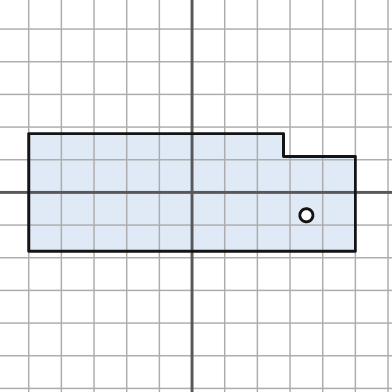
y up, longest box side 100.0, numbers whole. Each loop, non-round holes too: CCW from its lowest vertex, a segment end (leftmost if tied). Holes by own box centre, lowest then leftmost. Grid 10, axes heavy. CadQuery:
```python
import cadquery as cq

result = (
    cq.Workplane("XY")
    .moveTo(-50.0, -18.0)
    .lineTo(50.0, -18.0)
    .lineTo(50.0, 11.0)
    .lineTo(28.0, 11.0)
    .lineTo(28.0, 18.0)
    .lineTo(-50.0, 18.0)
    .close()
    .moveTo(35.0, -7.0)
    .circle(2.0)
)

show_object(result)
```